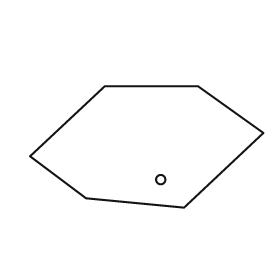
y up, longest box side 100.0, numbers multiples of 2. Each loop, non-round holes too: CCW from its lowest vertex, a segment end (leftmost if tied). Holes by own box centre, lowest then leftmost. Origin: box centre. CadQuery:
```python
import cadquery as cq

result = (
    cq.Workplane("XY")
    .moveTo(16.0, -26.0)
    .lineTo(50.0, 6.0)
    .lineTo(22.0, 26.0)
    .lineTo(-18.0, 26.0)
    .lineTo(-50.0, -4.0)
    .lineTo(-26.0, -22.0)
    .close()
    .moveTo(6.0, -14.0)
    .circle(2.0)
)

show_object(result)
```